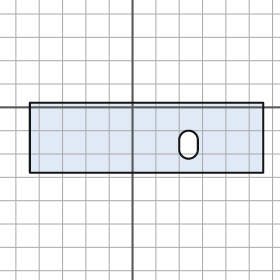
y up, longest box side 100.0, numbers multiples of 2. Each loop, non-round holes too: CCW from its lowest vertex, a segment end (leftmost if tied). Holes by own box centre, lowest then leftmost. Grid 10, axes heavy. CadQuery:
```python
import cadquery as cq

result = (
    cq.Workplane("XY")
    .moveTo(-44.0, -28.0)
    .lineTo(56.0, -28.0)
    .lineTo(56.0, 2.0)
    .lineTo(-44.0, 2.0)
    .close()
    .moveTo(20.0, -18.0)
    .threePointArc((24.0, -22.0), (28.0, -18.0))
    .lineTo(28.0, -14.0)
    .threePointArc((24.0, -10.0), (20.0, -14.0))
    .close()
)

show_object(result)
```